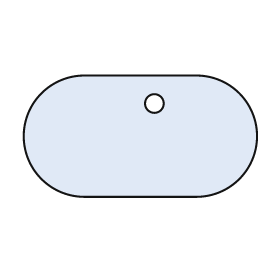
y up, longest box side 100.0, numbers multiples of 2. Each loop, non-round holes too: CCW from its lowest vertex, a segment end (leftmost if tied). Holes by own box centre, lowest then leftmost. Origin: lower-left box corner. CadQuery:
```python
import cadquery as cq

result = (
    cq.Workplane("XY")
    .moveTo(26.0, 0.0)
    .lineTo(74.0, 0.0)
    .threePointArc((100.0, 26.0), (74.0, 52.0))
    .lineTo(26.0, 52.0)
    .threePointArc((0.0, 26.0), (26.0, 0.0))
    .close()
    .moveTo(56.0, 40.0)
    .circle(4.0)
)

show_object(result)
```